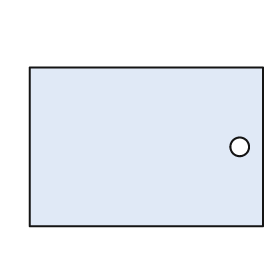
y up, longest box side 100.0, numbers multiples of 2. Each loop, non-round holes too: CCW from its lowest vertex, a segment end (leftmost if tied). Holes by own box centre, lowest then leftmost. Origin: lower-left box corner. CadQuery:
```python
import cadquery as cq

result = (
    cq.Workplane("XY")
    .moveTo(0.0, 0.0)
    .lineTo(100.0, 0.0)
    .lineTo(100.0, 68.0)
    .lineTo(0.0, 68.0)
    .close()
    .moveTo(90.0, 34.0)
    .circle(4.0)
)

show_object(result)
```